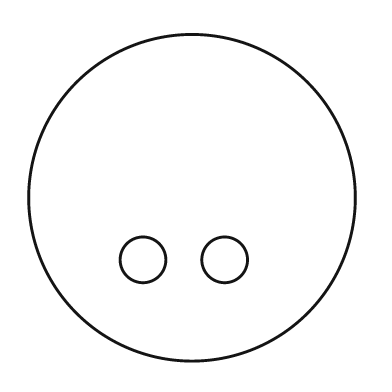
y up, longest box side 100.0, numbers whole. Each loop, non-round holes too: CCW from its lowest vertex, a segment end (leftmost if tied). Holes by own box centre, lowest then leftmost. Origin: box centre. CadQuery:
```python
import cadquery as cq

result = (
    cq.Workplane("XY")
    .moveTo(0.0, 0.0)
    .circle(50.0)
    .moveTo(-15.0, -19.0)
    .circle(7.0)
    .moveTo(10.0, -19.0)
    .circle(7.0)
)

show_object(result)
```